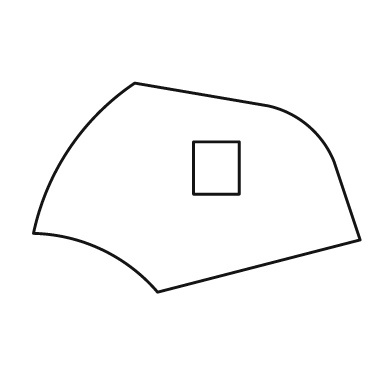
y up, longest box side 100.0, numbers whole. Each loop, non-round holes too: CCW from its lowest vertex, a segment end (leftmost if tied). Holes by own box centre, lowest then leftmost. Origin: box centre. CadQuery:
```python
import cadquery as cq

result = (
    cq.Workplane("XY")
    .moveTo(-12.0, -32.0)
    .lineTo(50.0, -16.0)
    .lineTo(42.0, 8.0)
    .threePointArc((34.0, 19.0), (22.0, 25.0))
    .lineTo(-19.0, 32.0)
    .threePointArc((-39.0, 12.0), (-50.0, -14.0))
    .threePointArc((-29.0, -19.0), (-12.0, -32.0))
    .close()
    .moveTo(-1.0, -2.0)
    .lineTo(13.0, -2.0)
    .lineTo(13.0, 14.0)
    .lineTo(-1.0, 14.0)
    .close()
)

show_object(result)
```